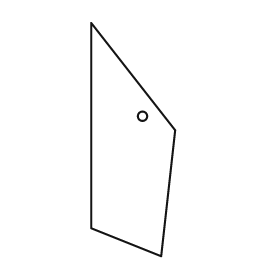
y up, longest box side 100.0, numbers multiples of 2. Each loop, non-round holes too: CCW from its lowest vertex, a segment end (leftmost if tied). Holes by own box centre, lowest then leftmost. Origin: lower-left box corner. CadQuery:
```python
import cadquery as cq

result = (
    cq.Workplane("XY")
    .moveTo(30.0, 0.0)
    .lineTo(36.0, 54.0)
    .lineTo(0.0, 100.0)
    .lineTo(0.0, 12.0)
    .close()
    .moveTo(22.0, 60.0)
    .circle(2.0)
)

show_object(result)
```